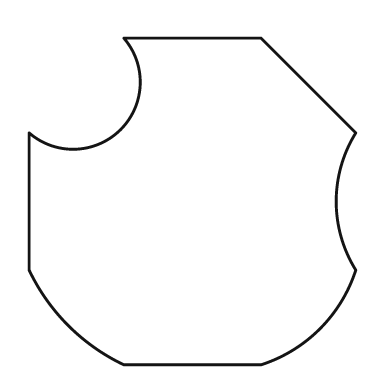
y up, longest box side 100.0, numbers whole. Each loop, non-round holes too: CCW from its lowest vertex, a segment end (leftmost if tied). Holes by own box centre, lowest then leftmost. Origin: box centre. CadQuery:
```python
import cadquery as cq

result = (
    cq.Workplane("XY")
    .moveTo(-21.0, -50.0)
    .lineTo(21.0, -50.0)
    .threePointArc((39.0, -39.0), (50.0, -21.0))
    .threePointArc((44.0, 0.0), (50.0, 21.0))
    .lineTo(21.0, 50.0)
    .lineTo(-21.0, 50.0)
    .threePointArc((-22.0, 22.0), (-50.0, 21.0))
    .lineTo(-50.0, -21.0)
    .threePointArc((-38.0, -38.0), (-21.0, -50.0))
    .close()
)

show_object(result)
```